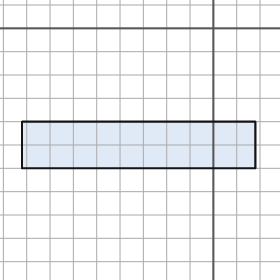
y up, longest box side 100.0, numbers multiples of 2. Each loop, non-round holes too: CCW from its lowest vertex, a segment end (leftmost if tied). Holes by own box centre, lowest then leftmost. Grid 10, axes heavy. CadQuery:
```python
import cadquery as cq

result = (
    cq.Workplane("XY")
    .moveTo(-82.0, -60.0)
    .lineTo(18.0, -60.0)
    .lineTo(18.0, -40.0)
    .lineTo(-82.0, -40.0)
    .close()
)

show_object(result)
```